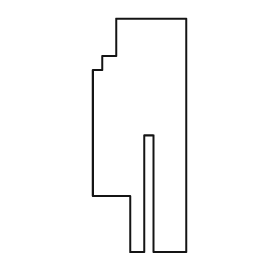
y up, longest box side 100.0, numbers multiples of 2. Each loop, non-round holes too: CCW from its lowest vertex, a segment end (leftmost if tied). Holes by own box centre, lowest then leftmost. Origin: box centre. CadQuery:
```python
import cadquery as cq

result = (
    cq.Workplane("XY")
    .moveTo(-4.0, -50.0)
    .lineTo(2.0, -50.0)
    .lineTo(2.0, 0.0)
    .lineTo(6.0, 0.0)
    .lineTo(6.0, -50.0)
    .lineTo(20.0, -50.0)
    .lineTo(20.0, 50.0)
    .lineTo(-10.0, 50.0)
    .lineTo(-10.0, 34.0)
    .lineTo(-16.0, 34.0)
    .lineTo(-16.0, 28.0)
    .lineTo(-20.0, 28.0)
    .lineTo(-20.0, -26.0)
    .lineTo(-4.0, -26.0)
    .close()
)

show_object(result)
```